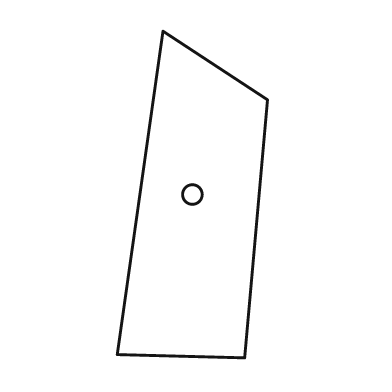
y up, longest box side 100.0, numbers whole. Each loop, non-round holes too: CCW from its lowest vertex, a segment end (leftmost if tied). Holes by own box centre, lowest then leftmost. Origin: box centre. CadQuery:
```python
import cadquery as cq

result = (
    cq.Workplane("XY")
    .moveTo(16.0, -50.0)
    .lineTo(23.0, 29.0)
    .lineTo(-9.0, 50.0)
    .lineTo(-23.0, -49.0)
    .close()
    .moveTo(0.0, 0.0)
    .circle(3.0)
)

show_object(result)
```